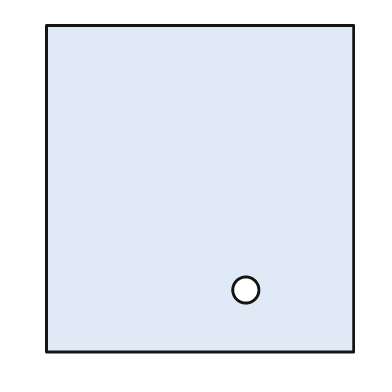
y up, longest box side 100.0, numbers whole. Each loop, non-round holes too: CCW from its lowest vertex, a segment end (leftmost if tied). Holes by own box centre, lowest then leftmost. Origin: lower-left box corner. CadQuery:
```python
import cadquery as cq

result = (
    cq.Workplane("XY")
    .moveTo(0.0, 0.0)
    .lineTo(94.0, 0.0)
    .lineTo(94.0, 100.0)
    .lineTo(0.0, 100.0)
    .close()
    .moveTo(61.0, 19.0)
    .circle(4.0)
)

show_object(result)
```